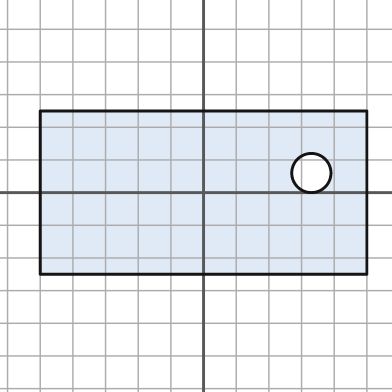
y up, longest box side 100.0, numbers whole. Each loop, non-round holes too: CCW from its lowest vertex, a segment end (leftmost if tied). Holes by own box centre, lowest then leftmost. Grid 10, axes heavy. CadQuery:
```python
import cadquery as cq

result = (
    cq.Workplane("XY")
    .moveTo(-50.0, -25.0)
    .lineTo(50.0, -25.0)
    .lineTo(50.0, 25.0)
    .lineTo(-50.0, 25.0)
    .close()
    .moveTo(33.0, 6.0)
    .circle(6.0)
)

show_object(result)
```